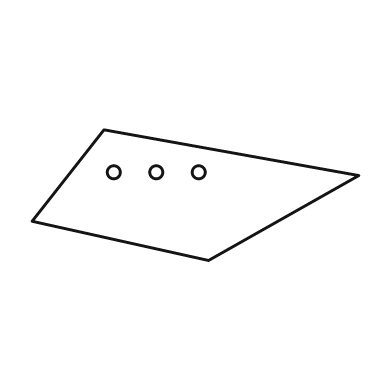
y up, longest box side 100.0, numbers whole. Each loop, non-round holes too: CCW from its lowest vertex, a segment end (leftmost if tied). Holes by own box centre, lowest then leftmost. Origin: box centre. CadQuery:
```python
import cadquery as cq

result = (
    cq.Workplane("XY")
    .moveTo(4.0, -20.0)
    .lineTo(50.0, 6.0)
    .lineTo(-28.0, 20.0)
    .lineTo(-50.0, -8.0)
    .close()
    .moveTo(-25.0, 7.0)
    .circle(2.0)
    .moveTo(-12.0, 7.0)
    .circle(2.0)
    .moveTo(1.0, 7.0)
    .circle(2.0)
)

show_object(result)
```